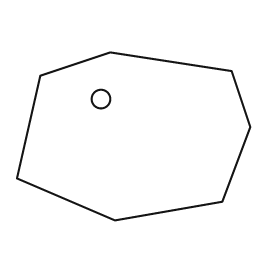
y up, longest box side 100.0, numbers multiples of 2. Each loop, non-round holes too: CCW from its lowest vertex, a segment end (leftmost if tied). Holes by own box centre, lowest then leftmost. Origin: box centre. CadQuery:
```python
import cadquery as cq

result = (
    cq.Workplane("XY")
    .moveTo(-8.0, -36.0)
    .lineTo(38.0, -28.0)
    .lineTo(50.0, 4.0)
    .lineTo(42.0, 28.0)
    .lineTo(-10.0, 36.0)
    .lineTo(-40.0, 26.0)
    .lineTo(-50.0, -18.0)
    .close()
    .moveTo(-14.0, 16.0)
    .circle(4.0)
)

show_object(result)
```